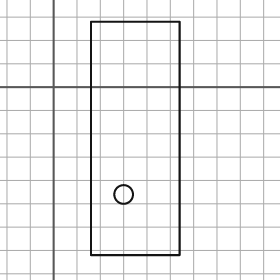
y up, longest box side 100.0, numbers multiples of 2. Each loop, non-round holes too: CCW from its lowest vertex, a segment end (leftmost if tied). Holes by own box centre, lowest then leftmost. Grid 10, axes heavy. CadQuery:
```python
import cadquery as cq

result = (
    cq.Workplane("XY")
    .moveTo(16.0, -72.0)
    .lineTo(54.0, -72.0)
    .lineTo(54.0, 28.0)
    .lineTo(16.0, 28.0)
    .close()
    .moveTo(30.0, -46.0)
    .circle(4.0)
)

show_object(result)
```